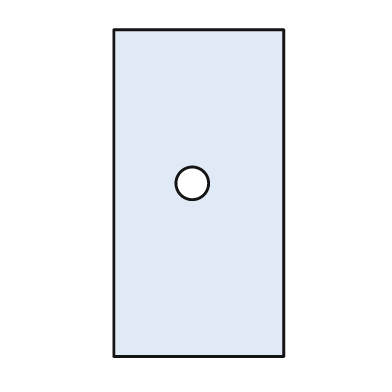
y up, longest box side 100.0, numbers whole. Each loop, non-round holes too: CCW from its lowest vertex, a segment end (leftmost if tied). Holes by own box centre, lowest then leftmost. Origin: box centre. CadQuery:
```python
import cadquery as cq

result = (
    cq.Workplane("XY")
    .moveTo(-26.0, -50.0)
    .lineTo(26.0, -50.0)
    .lineTo(26.0, 50.0)
    .lineTo(-26.0, 50.0)
    .close()
    .moveTo(-2.0, 3.0)
    .circle(5.0)
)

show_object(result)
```